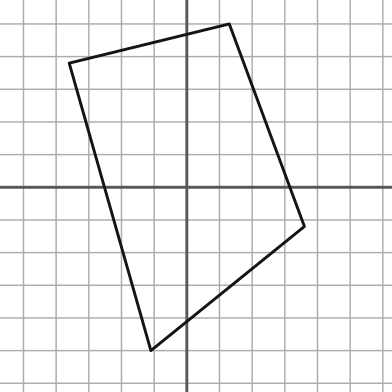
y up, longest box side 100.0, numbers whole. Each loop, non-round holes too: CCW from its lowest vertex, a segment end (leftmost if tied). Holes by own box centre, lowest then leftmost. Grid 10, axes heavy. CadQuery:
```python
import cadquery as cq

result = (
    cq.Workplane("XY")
    .moveTo(-11.0, -50.0)
    .lineTo(36.0, -12.0)
    .lineTo(13.0, 50.0)
    .lineTo(-36.0, 38.0)
    .close()
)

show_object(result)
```